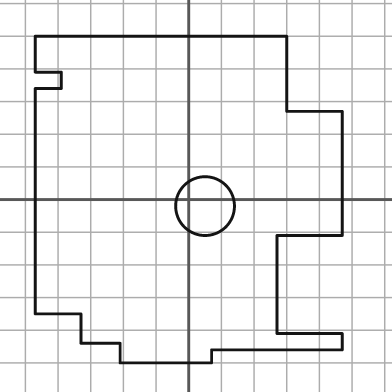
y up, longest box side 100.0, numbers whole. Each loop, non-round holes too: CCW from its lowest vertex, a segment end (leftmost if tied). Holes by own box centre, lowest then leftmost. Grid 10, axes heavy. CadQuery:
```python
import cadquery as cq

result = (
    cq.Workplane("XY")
    .moveTo(-21.0, -50.0)
    .lineTo(7.0, -50.0)
    .lineTo(7.0, -46.0)
    .lineTo(47.0, -46.0)
    .lineTo(47.0, -41.0)
    .lineTo(27.0, -41.0)
    .lineTo(27.0, -11.0)
    .lineTo(47.0, -11.0)
    .lineTo(47.0, 27.0)
    .lineTo(30.0, 27.0)
    .lineTo(30.0, 50.0)
    .lineTo(-47.0, 50.0)
    .lineTo(-47.0, 39.0)
    .lineTo(-39.0, 39.0)
    .lineTo(-39.0, 34.0)
    .lineTo(-47.0, 34.0)
    .lineTo(-47.0, -35.0)
    .lineTo(-33.0, -35.0)
    .lineTo(-33.0, -44.0)
    .lineTo(-21.0, -44.0)
    .close()
    .moveTo(5.0, -2.0)
    .circle(9.0)
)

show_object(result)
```